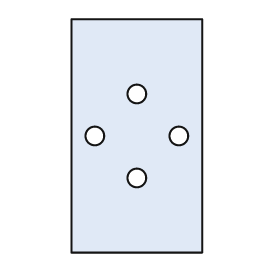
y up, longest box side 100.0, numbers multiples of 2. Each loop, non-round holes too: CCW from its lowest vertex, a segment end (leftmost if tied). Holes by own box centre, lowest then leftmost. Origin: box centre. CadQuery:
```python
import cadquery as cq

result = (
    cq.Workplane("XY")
    .moveTo(-28.0, -50.0)
    .lineTo(28.0, -50.0)
    .lineTo(28.0, 50.0)
    .lineTo(-28.0, 50.0)
    .close()
    .moveTo(0.0, -18.0)
    .circle(4.0)
    .moveTo(-18.0, 0.0)
    .circle(4.0)
    .moveTo(18.0, 0.0)
    .circle(4.0)
    .moveTo(0.0, 18.0)
    .circle(4.0)
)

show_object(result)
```